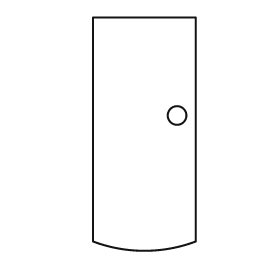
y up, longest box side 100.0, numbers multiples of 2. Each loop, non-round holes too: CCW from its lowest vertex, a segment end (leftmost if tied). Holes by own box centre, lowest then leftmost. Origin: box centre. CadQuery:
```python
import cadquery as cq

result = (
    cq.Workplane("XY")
    .moveTo(-22.0, -46.0)
    .threePointArc((0.0, -50.0), (22.0, -46.0))
    .lineTo(22.0, 50.0)
    .lineTo(-22.0, 50.0)
    .close()
    .moveTo(14.0, 8.0)
    .circle(4.0)
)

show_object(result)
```